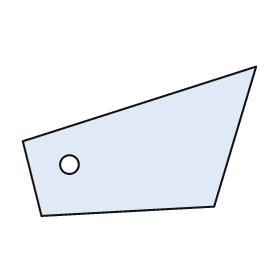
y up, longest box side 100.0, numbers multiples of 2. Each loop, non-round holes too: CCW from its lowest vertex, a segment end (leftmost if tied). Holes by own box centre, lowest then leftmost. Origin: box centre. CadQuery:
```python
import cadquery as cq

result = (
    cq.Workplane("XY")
    .moveTo(-42.0, -32.0)
    .lineTo(32.0, -28.0)
    .lineTo(50.0, 32.0)
    .lineTo(-50.0, 0.0)
    .close()
    .moveTo(-30.0, -10.0)
    .circle(4.0)
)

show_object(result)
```